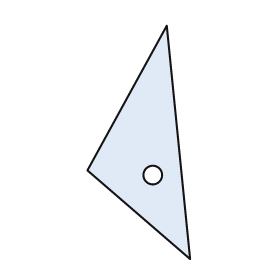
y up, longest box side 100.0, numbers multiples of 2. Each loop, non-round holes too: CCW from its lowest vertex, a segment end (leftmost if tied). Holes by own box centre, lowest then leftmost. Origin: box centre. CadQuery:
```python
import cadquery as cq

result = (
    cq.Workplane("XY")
    .moveTo(22.0, -50.0)
    .lineTo(12.0, 50.0)
    .lineTo(-22.0, -12.0)
    .close()
    .moveTo(6.0, -14.0)
    .circle(4.0)
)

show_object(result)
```